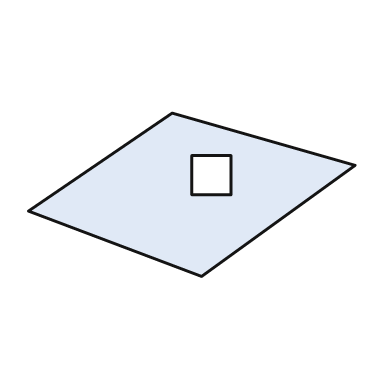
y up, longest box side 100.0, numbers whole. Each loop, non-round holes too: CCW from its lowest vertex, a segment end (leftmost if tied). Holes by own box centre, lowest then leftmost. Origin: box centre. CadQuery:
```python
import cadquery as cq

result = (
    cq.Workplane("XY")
    .moveTo(3.0, -25.0)
    .lineTo(50.0, 9.0)
    .lineTo(-6.0, 25.0)
    .lineTo(-50.0, -5.0)
    .close()
    .moveTo(0.0, 0.0)
    .lineTo(12.0, 0.0)
    .lineTo(12.0, 12.0)
    .lineTo(0.0, 12.0)
    .close()
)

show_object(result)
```